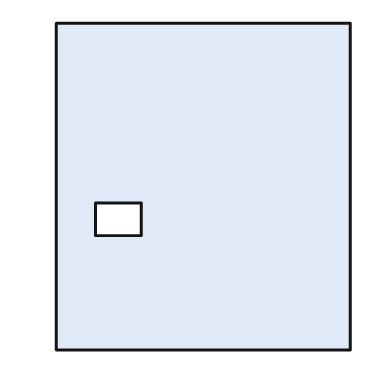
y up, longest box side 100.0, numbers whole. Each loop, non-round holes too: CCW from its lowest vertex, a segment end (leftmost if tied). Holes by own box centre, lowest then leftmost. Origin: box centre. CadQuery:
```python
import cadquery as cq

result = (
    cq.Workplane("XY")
    .moveTo(-45.0, -50.0)
    .lineTo(45.0, -50.0)
    .lineTo(45.0, 50.0)
    .lineTo(-45.0, 50.0)
    .close()
    .moveTo(-33.0, -15.0)
    .lineTo(-19.0, -15.0)
    .lineTo(-19.0, -5.0)
    .lineTo(-33.0, -5.0)
    .close()
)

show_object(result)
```